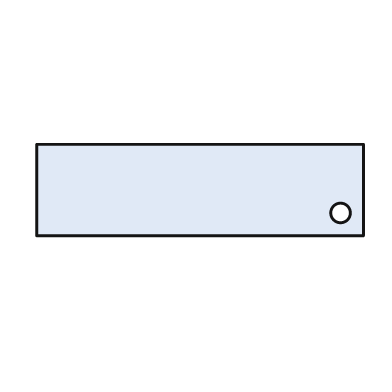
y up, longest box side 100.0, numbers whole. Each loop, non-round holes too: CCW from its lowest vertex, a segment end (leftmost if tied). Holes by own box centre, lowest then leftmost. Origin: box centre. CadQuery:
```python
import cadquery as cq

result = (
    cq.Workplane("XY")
    .moveTo(-50.0, -14.0)
    .lineTo(50.0, -14.0)
    .lineTo(50.0, 14.0)
    .lineTo(-50.0, 14.0)
    .close()
    .moveTo(43.0, -7.0)
    .circle(3.0)
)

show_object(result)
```